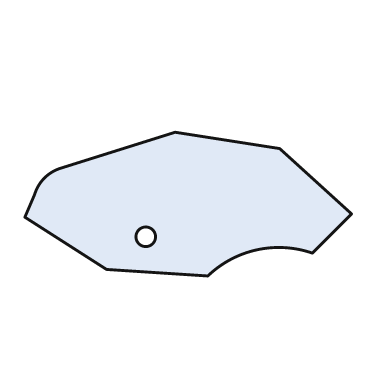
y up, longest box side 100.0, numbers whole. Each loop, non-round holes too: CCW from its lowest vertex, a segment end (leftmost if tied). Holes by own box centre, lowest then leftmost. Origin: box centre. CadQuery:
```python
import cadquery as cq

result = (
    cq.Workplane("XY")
    .moveTo(6.0, -22.0)
    .threePointArc((21.0, -14.0), (38.0, -15.0))
    .lineTo(50.0, -3.0)
    .lineTo(28.0, 17.0)
    .lineTo(-4.0, 22.0)
    .lineTo(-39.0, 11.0)
    .threePointArc((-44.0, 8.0), (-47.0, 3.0))
    .lineTo(-50.0, -4.0)
    .lineTo(-25.0, -20.0)
    .close()
    .moveTo(-13.0, -10.0)
    .circle(3.0)
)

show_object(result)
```